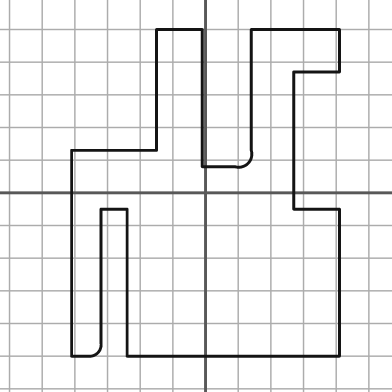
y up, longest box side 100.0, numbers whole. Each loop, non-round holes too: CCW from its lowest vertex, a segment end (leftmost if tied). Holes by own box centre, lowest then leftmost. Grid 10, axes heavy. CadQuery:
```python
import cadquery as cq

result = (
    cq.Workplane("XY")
    .moveTo(-41.0, -50.0)
    .lineTo(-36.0, -50.0)
    .threePointArc((-33.0, -49.0), (-32.0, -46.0))
    .lineTo(-32.0, -5.0)
    .lineTo(-24.0, -5.0)
    .lineTo(-24.0, -50.0)
    .lineTo(41.0, -50.0)
    .lineTo(41.0, -5.0)
    .lineTo(27.0, -5.0)
    .lineTo(27.0, 37.0)
    .lineTo(41.0, 37.0)
    .lineTo(41.0, 50.0)
    .lineTo(14.0, 50.0)
    .lineTo(14.0, 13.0)
    .threePointArc((13.0, 9.0), (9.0, 8.0))
    .lineTo(-1.0, 8.0)
    .lineTo(-1.0, 50.0)
    .lineTo(-15.0, 50.0)
    .lineTo(-15.0, 13.0)
    .lineTo(-41.0, 13.0)
    .close()
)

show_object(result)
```